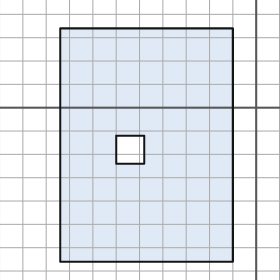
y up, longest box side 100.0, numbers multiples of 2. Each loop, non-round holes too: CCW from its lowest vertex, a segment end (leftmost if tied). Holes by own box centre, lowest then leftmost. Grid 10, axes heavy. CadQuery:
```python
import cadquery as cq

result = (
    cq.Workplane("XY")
    .moveTo(-84.0, -66.0)
    .lineTo(-10.0, -66.0)
    .lineTo(-10.0, 34.0)
    .lineTo(-84.0, 34.0)
    .close()
    .moveTo(-60.0, -24.0)
    .lineTo(-48.0, -24.0)
    .lineTo(-48.0, -12.0)
    .lineTo(-60.0, -12.0)
    .close()
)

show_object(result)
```